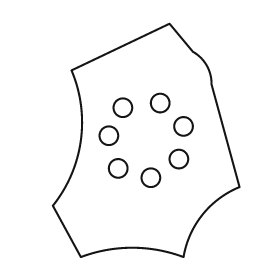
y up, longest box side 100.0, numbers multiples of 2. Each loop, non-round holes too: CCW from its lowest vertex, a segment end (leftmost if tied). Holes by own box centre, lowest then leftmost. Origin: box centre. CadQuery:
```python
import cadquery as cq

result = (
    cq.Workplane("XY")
    .moveTo(-28.0, -50.0)
    .threePointArc((-6.0, -46.0), (16.0, -50.0))
    .threePointArc((24.0, -32.0), (40.0, -20.0))
    .lineTo(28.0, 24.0)
    .threePointArc((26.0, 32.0), (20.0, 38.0))
    .lineTo(10.0, 50.0)
    .lineTo(-32.0, 30.0)
    .threePointArc((-28.0, 0.0), (-40.0, -28.0))
    .close()
    .moveTo(2.0, -16.0)
    .circle(4.0)
    .moveTo(-12.0, -12.0)
    .circle(4.0)
    .moveTo(14.0, -8.0)
    .circle(4.0)
    .moveTo(-16.0, 2.0)
    .circle(4.0)
    .moveTo(16.0, 6.0)
    .circle(4.0)
    .moveTo(-10.0, 14.0)
    .circle(4.0)
    .moveTo(6.0, 16.0)
    .circle(4.0)
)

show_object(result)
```